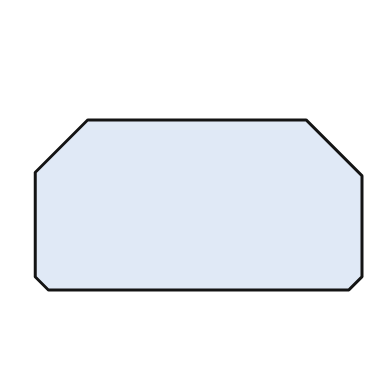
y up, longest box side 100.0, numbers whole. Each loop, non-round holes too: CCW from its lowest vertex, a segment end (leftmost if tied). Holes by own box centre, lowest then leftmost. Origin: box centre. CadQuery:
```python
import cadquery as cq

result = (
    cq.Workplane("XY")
    .moveTo(-46.0, -26.0)
    .lineTo(46.0, -26.0)
    .lineTo(50.0, -22.0)
    .lineTo(50.0, 9.0)
    .lineTo(33.0, 26.0)
    .lineTo(-34.0, 26.0)
    .lineTo(-50.0, 10.0)
    .lineTo(-50.0, -22.0)
    .close()
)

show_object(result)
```